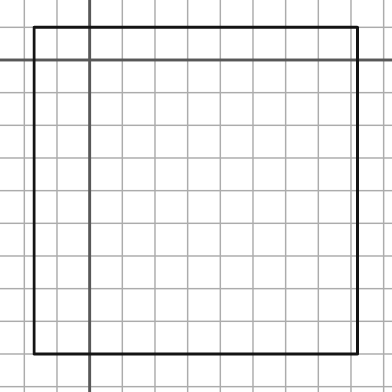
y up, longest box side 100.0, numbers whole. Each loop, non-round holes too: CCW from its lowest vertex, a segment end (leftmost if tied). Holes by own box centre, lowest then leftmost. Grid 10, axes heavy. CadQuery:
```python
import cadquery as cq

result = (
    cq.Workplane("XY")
    .moveTo(-17.0, -90.0)
    .lineTo(82.0, -90.0)
    .lineTo(82.0, 10.0)
    .lineTo(-17.0, 10.0)
    .close()
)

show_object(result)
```